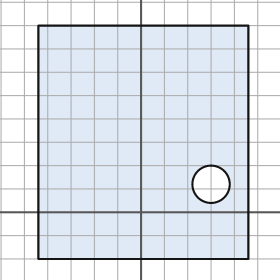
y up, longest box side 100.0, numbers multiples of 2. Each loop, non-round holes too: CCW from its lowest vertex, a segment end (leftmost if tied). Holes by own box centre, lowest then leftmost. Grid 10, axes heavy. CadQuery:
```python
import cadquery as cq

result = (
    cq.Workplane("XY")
    .moveTo(-44.0, -20.0)
    .lineTo(46.0, -20.0)
    .lineTo(46.0, 80.0)
    .lineTo(-44.0, 80.0)
    .close()
    .moveTo(30.0, 12.0)
    .circle(8.0)
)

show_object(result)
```